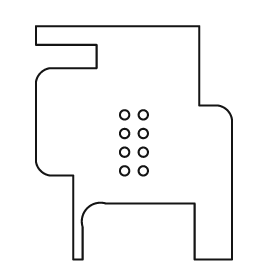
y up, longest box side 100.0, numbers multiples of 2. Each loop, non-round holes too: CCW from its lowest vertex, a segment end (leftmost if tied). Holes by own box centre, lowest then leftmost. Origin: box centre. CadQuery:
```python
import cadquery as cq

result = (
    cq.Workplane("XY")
    .moveTo(-26.0, -50.0)
    .lineTo(-22.0, -50.0)
    .lineTo(-22.0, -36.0)
    .threePointArc((-20.0, -28.0), (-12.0, -26.0))
    .lineTo(26.0, -26.0)
    .lineTo(26.0, -50.0)
    .lineTo(42.0, -50.0)
    .lineTo(42.0, 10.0)
    .threePointArc((40.0, 14.0), (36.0, 16.0))
    .lineTo(28.0, 16.0)
    .lineTo(28.0, 50.0)
    .lineTo(-42.0, 50.0)
    .lineTo(-42.0, 42.0)
    .lineTo(-16.0, 42.0)
    .lineTo(-16.0, 32.0)
    .lineTo(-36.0, 32.0)
    .threePointArc((-40.0, 30.0), (-42.0, 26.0))
    .lineTo(-42.0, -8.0)
    .threePointArc((-40.0, -12.0), (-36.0, -14.0))
    .lineTo(-26.0, -14.0)
    .close()
    .moveTo(-4.0, -12.0)
    .circle(2.0)
    .moveTo(4.0, -12.0)
    .circle(2.0)
    .moveTo(-4.0, -4.0)
    .circle(2.0)
    .moveTo(4.0, -4.0)
    .circle(2.0)
    .moveTo(-4.0, 4.0)
    .circle(2.0)
    .moveTo(4.0, 4.0)
    .circle(2.0)
    .moveTo(-4.0, 12.0)
    .circle(2.0)
    .moveTo(4.0, 12.0)
    .circle(2.0)
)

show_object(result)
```